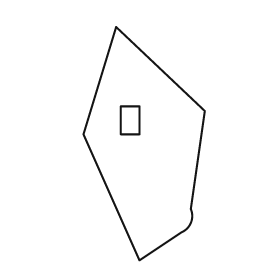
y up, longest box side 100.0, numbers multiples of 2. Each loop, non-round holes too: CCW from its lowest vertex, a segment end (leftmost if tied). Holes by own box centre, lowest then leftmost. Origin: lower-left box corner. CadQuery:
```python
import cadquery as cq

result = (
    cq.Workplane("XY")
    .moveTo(24.0, 0.0)
    .lineTo(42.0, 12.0)
    .threePointArc((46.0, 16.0), (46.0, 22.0))
    .lineTo(52.0, 64.0)
    .lineTo(14.0, 100.0)
    .lineTo(0.0, 54.0)
    .close()
    .moveTo(16.0, 54.0)
    .lineTo(24.0, 54.0)
    .lineTo(24.0, 66.0)
    .lineTo(16.0, 66.0)
    .close()
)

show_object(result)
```